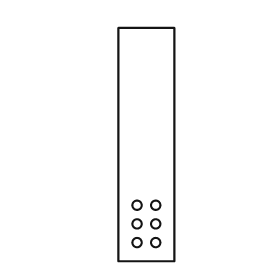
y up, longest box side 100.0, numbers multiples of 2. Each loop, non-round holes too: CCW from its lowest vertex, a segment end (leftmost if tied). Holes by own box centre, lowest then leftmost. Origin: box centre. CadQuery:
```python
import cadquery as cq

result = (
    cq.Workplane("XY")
    .moveTo(-12.0, -50.0)
    .lineTo(12.0, -50.0)
    .lineTo(12.0, 50.0)
    .lineTo(-12.0, 50.0)
    .close()
    .moveTo(-4.0, -42.0)
    .circle(2.0)
    .moveTo(4.0, -42.0)
    .circle(2.0)
    .moveTo(-4.0, -34.0)
    .circle(2.0)
    .moveTo(4.0, -34.0)
    .circle(2.0)
    .moveTo(-4.0, -26.0)
    .circle(2.0)
    .moveTo(4.0, -26.0)
    .circle(2.0)
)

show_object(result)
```